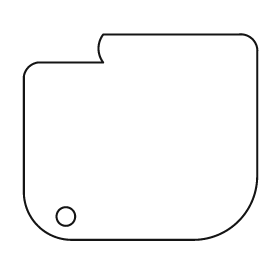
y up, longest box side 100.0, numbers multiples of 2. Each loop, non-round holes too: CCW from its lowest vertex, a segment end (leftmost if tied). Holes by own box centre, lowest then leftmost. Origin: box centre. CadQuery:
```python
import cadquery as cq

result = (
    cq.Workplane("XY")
    .moveTo(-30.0, -44.0)
    .lineTo(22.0, -44.0)
    .threePointArc((42.0, -36.0), (50.0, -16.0))
    .lineTo(50.0, 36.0)
    .threePointArc((48.0, 42.0), (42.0, 44.0))
    .lineTo(-16.0, 44.0)
    .threePointArc((-18.0, 38.0), (-16.0, 32.0))
    .lineTo(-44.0, 32.0)
    .threePointArc((-48.0, 30.0), (-50.0, 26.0))
    .lineTo(-50.0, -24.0)
    .threePointArc((-44.0, -38.0), (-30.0, -44.0))
    .close()
    .moveTo(-32.0, -34.0)
    .circle(4.0)
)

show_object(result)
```